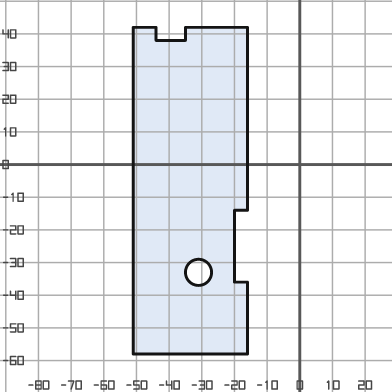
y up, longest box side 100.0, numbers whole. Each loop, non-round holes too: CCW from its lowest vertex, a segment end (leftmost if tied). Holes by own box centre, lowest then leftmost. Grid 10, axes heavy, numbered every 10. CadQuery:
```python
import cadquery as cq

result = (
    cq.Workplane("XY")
    .moveTo(-51.0, -58.0)
    .lineTo(-16.0, -58.0)
    .lineTo(-16.0, -36.0)
    .lineTo(-20.0, -36.0)
    .lineTo(-20.0, -14.0)
    .lineTo(-16.0, -14.0)
    .lineTo(-16.0, 42.0)
    .lineTo(-35.0, 42.0)
    .lineTo(-35.0, 38.0)
    .lineTo(-44.0, 38.0)
    .lineTo(-44.0, 42.0)
    .lineTo(-51.0, 42.0)
    .close()
    .moveTo(-31.0, -33.0)
    .circle(4.0)
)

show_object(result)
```